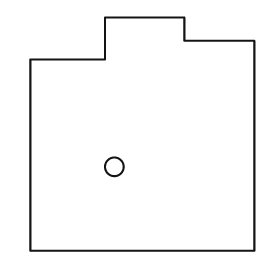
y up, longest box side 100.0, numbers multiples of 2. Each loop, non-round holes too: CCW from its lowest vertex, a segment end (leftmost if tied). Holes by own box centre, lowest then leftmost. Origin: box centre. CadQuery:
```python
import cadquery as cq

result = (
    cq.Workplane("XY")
    .moveTo(-48.0, -50.0)
    .lineTo(48.0, -50.0)
    .lineTo(48.0, 40.0)
    .lineTo(18.0, 40.0)
    .lineTo(18.0, 50.0)
    .lineTo(-16.0, 50.0)
    .lineTo(-16.0, 32.0)
    .lineTo(-48.0, 32.0)
    .close()
    .moveTo(-12.0, -14.0)
    .circle(4.0)
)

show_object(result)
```